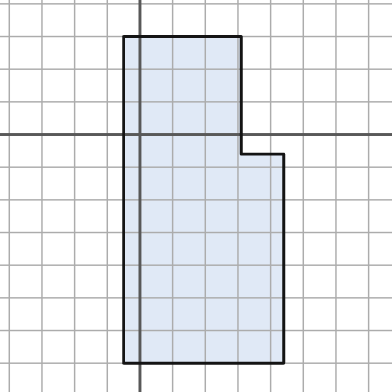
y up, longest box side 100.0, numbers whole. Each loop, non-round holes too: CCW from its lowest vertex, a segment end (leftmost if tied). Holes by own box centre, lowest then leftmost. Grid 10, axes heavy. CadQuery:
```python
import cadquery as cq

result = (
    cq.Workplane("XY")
    .moveTo(-5.0, -70.0)
    .lineTo(44.0, -70.0)
    .lineTo(44.0, -6.0)
    .lineTo(31.0, -6.0)
    .lineTo(31.0, 30.0)
    .lineTo(-5.0, 30.0)
    .close()
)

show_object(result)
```